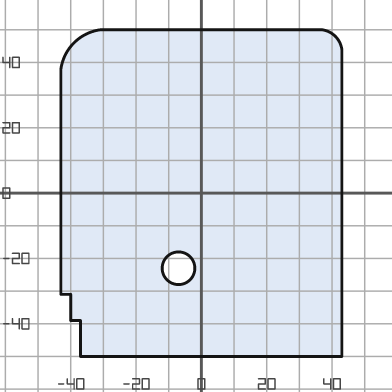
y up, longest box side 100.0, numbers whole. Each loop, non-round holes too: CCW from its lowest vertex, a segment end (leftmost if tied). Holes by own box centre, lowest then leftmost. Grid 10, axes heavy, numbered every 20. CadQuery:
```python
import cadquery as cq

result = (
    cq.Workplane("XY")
    .moveTo(-37.0, -50.0)
    .lineTo(43.0, -50.0)
    .lineTo(43.0, 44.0)
    .threePointArc((41.0, 48.0), (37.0, 50.0))
    .lineTo(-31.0, 50.0)
    .threePointArc((-39.0, 46.0), (-43.0, 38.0))
    .lineTo(-43.0, -31.0)
    .lineTo(-40.0, -31.0)
    .lineTo(-40.0, -39.0)
    .lineTo(-37.0, -39.0)
    .close()
    .moveTo(-7.0, -23.0)
    .circle(5.0)
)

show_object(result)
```